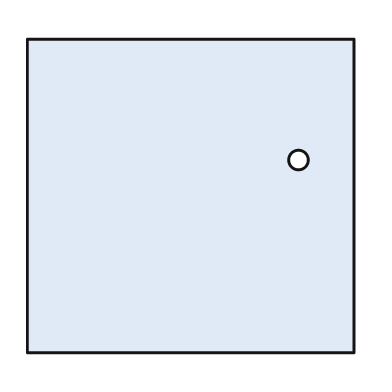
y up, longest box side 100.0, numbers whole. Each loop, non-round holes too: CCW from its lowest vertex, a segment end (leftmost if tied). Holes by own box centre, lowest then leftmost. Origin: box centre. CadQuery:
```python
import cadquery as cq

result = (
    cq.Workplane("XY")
    .moveTo(-50.0, -48.0)
    .lineTo(50.0, -48.0)
    .lineTo(50.0, 48.0)
    .lineTo(-50.0, 48.0)
    .close()
    .moveTo(33.0, 11.0)
    .circle(3.0)
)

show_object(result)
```